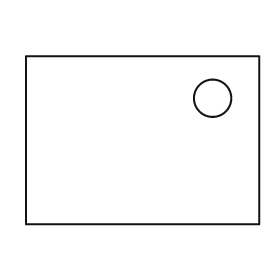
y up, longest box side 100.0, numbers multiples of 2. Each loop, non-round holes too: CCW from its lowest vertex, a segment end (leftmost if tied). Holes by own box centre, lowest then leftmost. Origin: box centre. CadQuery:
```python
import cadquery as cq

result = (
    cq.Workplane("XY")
    .moveTo(-50.0, -36.0)
    .lineTo(50.0, -36.0)
    .lineTo(50.0, 36.0)
    .lineTo(-50.0, 36.0)
    .close()
    .moveTo(30.0, 18.0)
    .circle(8.0)
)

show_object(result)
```